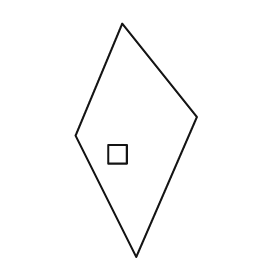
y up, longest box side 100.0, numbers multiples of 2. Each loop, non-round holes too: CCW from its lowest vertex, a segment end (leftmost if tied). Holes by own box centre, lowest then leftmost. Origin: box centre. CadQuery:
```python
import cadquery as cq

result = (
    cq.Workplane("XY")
    .moveTo(0.0, -50.0)
    .lineTo(26.0, 10.0)
    .lineTo(-6.0, 50.0)
    .lineTo(-26.0, 2.0)
    .close()
    .moveTo(-12.0, -10.0)
    .lineTo(-4.0, -10.0)
    .lineTo(-4.0, -2.0)
    .lineTo(-12.0, -2.0)
    .close()
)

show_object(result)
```